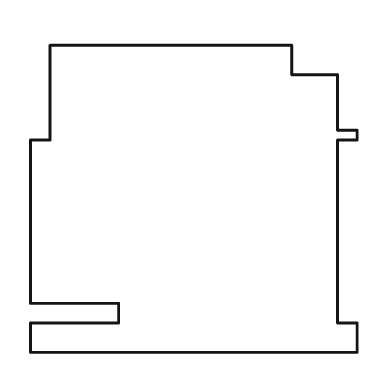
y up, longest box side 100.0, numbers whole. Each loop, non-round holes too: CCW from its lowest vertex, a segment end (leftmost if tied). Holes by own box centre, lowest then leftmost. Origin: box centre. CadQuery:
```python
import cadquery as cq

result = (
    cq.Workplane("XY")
    .moveTo(-50.0, -47.0)
    .lineTo(50.0, -47.0)
    .lineTo(50.0, -38.0)
    .lineTo(44.0, -38.0)
    .lineTo(44.0, 18.0)
    .lineTo(50.0, 18.0)
    .lineTo(50.0, 21.0)
    .lineTo(44.0, 21.0)
    .lineTo(44.0, 38.0)
    .lineTo(30.0, 38.0)
    .lineTo(30.0, 47.0)
    .lineTo(-44.0, 47.0)
    .lineTo(-44.0, 18.0)
    .lineTo(-50.0, 18.0)
    .lineTo(-50.0, -32.0)
    .lineTo(-23.0, -32.0)
    .lineTo(-23.0, -38.0)
    .lineTo(-50.0, -38.0)
    .close()
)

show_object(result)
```